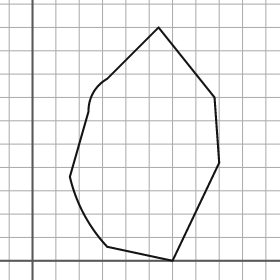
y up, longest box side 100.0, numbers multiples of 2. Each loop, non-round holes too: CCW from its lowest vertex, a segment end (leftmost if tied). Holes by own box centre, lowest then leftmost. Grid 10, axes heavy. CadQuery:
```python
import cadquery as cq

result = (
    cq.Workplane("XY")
    .moveTo(60.0, 0.0)
    .lineTo(80.0, 42.0)
    .lineTo(78.0, 70.0)
    .lineTo(54.0, 100.0)
    .lineTo(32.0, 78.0)
    .threePointArc((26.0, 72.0), (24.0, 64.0))
    .lineTo(16.0, 36.0)
    .threePointArc((22.0, 20.0), (32.0, 6.0))
    .close()
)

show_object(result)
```